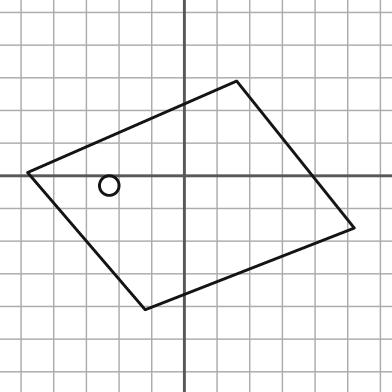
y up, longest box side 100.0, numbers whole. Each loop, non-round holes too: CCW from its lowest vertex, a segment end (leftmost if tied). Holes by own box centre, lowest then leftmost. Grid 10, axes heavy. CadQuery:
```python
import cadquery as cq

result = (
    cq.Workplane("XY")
    .moveTo(-12.0, -41.0)
    .lineTo(52.0, -16.0)
    .lineTo(16.0, 29.0)
    .lineTo(-48.0, 1.0)
    .close()
    .moveTo(-23.0, -3.0)
    .circle(3.0)
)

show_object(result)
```